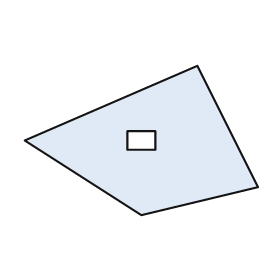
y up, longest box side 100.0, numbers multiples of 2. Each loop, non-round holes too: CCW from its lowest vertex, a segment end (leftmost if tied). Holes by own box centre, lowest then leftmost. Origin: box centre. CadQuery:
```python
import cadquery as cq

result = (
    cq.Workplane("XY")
    .moveTo(0.0, -32.0)
    .lineTo(50.0, -20.0)
    .lineTo(24.0, 32.0)
    .lineTo(-50.0, 0.0)
    .close()
    .moveTo(-6.0, -4.0)
    .lineTo(6.0, -4.0)
    .lineTo(6.0, 4.0)
    .lineTo(-6.0, 4.0)
    .close()
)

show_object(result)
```